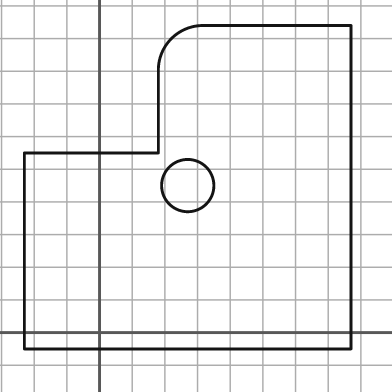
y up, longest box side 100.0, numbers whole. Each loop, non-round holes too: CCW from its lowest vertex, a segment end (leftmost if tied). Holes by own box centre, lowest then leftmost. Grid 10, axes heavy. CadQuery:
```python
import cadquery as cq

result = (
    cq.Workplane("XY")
    .moveTo(-23.0, -5.0)
    .lineTo(77.0, -5.0)
    .lineTo(77.0, 94.0)
    .lineTo(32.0, 94.0)
    .threePointArc((22.0, 90.0), (18.0, 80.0))
    .lineTo(18.0, 55.0)
    .lineTo(-23.0, 55.0)
    .close()
    .moveTo(27.0, 45.0)
    .circle(8.0)
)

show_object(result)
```